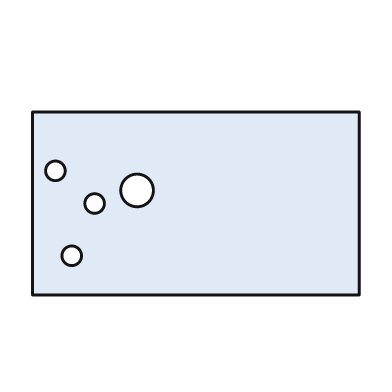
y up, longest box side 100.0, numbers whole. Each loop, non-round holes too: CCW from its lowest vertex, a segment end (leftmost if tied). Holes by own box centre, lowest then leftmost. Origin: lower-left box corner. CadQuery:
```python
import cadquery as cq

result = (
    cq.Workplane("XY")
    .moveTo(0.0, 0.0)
    .lineTo(100.0, 0.0)
    .lineTo(100.0, 56.0)
    .lineTo(0.0, 56.0)
    .close()
    .moveTo(12.0, 12.0)
    .circle(3.0)
    .moveTo(19.0, 28.0)
    .circle(3.0)
    .moveTo(32.0, 32.0)
    .circle(5.0)
    .moveTo(7.0, 38.0)
    .circle(3.0)
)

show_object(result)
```